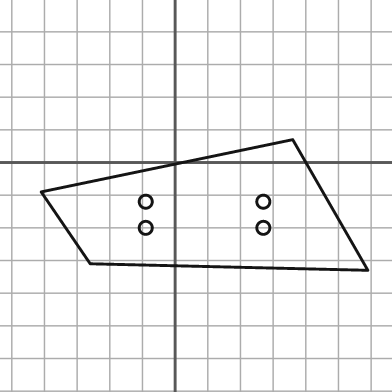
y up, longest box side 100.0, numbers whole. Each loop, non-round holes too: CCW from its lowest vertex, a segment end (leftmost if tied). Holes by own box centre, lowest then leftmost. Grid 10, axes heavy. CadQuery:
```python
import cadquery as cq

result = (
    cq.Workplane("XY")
    .moveTo(59.0, -33.0)
    .lineTo(36.0, 7.0)
    .lineTo(-41.0, -9.0)
    .lineTo(-26.0, -31.0)
    .close()
    .moveTo(-9.0, -20.0)
    .circle(2.0)
    .moveTo(27.0, -20.0)
    .circle(2.0)
    .moveTo(-9.0, -12.0)
    .circle(2.0)
    .moveTo(27.0, -12.0)
    .circle(2.0)
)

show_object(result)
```